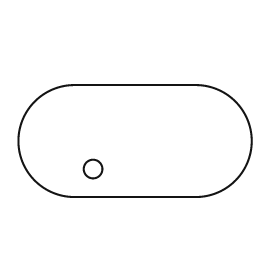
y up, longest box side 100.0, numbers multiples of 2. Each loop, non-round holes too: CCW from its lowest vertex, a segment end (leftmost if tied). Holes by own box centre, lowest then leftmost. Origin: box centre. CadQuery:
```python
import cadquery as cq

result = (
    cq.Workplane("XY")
    .moveTo(-26.0, -24.0)
    .lineTo(26.0, -24.0)
    .threePointArc((50.0, 0.0), (26.0, 24.0))
    .lineTo(-26.0, 24.0)
    .threePointArc((-50.0, 0.0), (-26.0, -24.0))
    .close()
    .moveTo(-18.0, -12.0)
    .circle(4.0)
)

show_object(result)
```